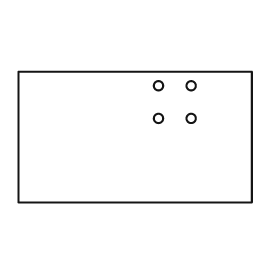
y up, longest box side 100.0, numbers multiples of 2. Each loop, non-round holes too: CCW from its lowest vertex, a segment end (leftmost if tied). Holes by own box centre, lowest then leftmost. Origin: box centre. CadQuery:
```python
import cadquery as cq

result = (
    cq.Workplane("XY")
    .moveTo(-50.0, -28.0)
    .lineTo(50.0, -28.0)
    .lineTo(50.0, 28.0)
    .lineTo(-50.0, 28.0)
    .close()
    .moveTo(10.0, 8.0)
    .circle(2.0)
    .moveTo(24.0, 8.0)
    .circle(2.0)
    .moveTo(10.0, 22.0)
    .circle(2.0)
    .moveTo(24.0, 22.0)
    .circle(2.0)
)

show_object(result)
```